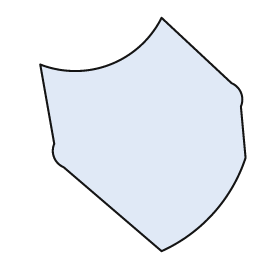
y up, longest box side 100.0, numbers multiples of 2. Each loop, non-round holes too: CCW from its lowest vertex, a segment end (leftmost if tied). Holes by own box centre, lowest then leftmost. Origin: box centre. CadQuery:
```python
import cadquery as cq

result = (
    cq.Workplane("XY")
    .moveTo(8.0, -50.0)
    .threePointArc((30.0, -34.0), (44.0, -10.0))
    .lineTo(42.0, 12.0)
    .threePointArc((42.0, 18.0), (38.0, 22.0))
    .lineTo(8.0, 50.0)
    .threePointArc((-14.0, 30.0), (-44.0, 30.0))
    .lineTo(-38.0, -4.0)
    .threePointArc((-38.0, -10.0), (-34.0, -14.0))
    .close()
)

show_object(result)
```